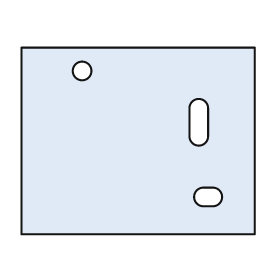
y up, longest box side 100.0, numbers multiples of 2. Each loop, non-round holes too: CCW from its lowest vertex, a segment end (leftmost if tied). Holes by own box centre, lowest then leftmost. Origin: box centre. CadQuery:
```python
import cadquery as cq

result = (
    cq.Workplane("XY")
    .moveTo(-50.0, -40.0)
    .lineTo(50.0, -40.0)
    .lineTo(50.0, 40.0)
    .lineTo(-50.0, 40.0)
    .close()
    .moveTo(28.0, -28.0)
    .lineTo(32.0, -28.0)
    .threePointArc((36.0, -24.0), (32.0, -20.0))
    .lineTo(28.0, -20.0)
    .threePointArc((24.0, -24.0), (28.0, -28.0))
    .close()
    .moveTo(22.0, 2.0)
    .threePointArc((26.0, -2.0), (30.0, 2.0))
    .lineTo(30.0, 14.0)
    .threePointArc((26.0, 18.0), (22.0, 14.0))
    .close()
    .moveTo(-24.0, 30.0)
    .circle(4.0)
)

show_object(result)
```